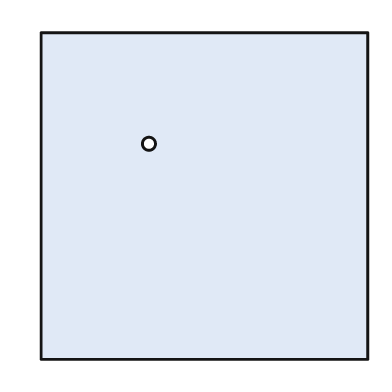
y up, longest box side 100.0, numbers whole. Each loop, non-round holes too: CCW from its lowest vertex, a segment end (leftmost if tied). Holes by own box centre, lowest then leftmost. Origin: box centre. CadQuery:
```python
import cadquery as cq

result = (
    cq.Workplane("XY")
    .moveTo(-50.0, -50.0)
    .lineTo(50.0, -50.0)
    .lineTo(50.0, 50.0)
    .lineTo(-50.0, 50.0)
    .close()
    .moveTo(-17.0, 16.0)
    .circle(2.0)
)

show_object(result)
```